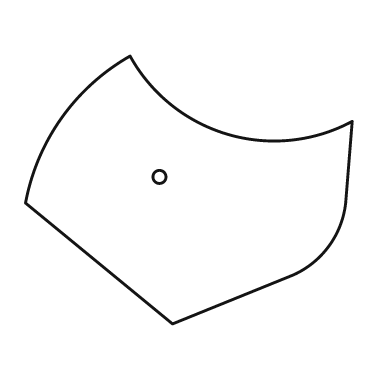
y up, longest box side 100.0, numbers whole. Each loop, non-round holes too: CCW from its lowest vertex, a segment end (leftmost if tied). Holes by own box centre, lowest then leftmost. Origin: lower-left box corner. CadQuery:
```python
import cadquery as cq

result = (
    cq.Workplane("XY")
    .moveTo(45.0, 0.0)
    .lineTo(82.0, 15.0)
    .threePointArc((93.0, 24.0), (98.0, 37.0))
    .lineTo(100.0, 62.0)
    .threePointArc((62.0, 58.0), (32.0, 82.0))
    .threePointArc((11.0, 63.0), (0.0, 37.0))
    .close()
    .moveTo(41.0, 45.0)
    .circle(2.0)
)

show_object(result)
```